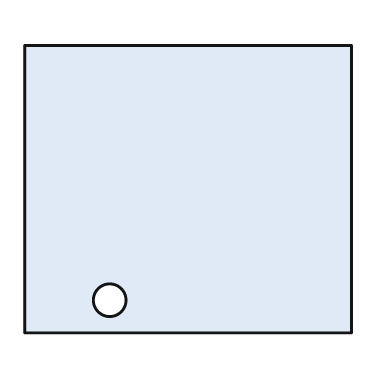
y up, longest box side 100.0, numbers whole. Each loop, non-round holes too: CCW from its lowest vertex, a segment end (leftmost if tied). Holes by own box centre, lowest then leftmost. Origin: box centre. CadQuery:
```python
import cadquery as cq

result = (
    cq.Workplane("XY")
    .moveTo(-50.0, -44.0)
    .lineTo(50.0, -44.0)
    .lineTo(50.0, 44.0)
    .lineTo(-50.0, 44.0)
    .close()
    .moveTo(-24.0, -34.0)
    .circle(5.0)
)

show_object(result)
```